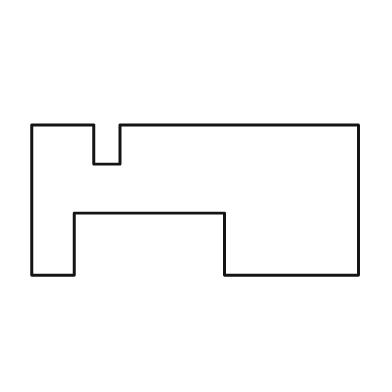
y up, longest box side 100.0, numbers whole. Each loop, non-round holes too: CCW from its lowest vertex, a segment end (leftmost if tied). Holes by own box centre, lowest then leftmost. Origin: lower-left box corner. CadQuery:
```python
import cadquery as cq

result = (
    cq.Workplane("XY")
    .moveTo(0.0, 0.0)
    .lineTo(13.0, 0.0)
    .lineTo(13.0, 19.0)
    .lineTo(59.0, 19.0)
    .lineTo(59.0, 0.0)
    .lineTo(100.0, 0.0)
    .lineTo(100.0, 46.0)
    .lineTo(27.0, 46.0)
    .lineTo(27.0, 34.0)
    .lineTo(19.0, 34.0)
    .lineTo(19.0, 46.0)
    .lineTo(0.0, 46.0)
    .close()
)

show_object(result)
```